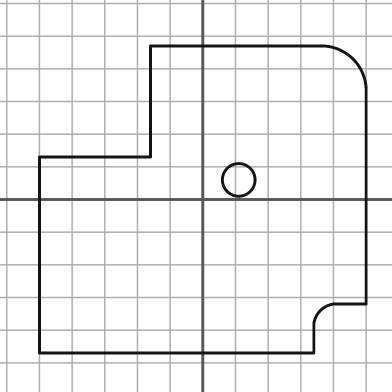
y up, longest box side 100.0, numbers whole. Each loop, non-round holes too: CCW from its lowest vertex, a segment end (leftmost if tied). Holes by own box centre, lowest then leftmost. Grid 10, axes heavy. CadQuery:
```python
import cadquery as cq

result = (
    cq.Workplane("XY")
    .moveTo(-50.0, -47.0)
    .lineTo(34.0, -47.0)
    .lineTo(34.0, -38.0)
    .threePointArc((36.0, -34.0), (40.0, -32.0))
    .lineTo(50.0, -32.0)
    .lineTo(50.0, 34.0)
    .threePointArc((46.0, 43.0), (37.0, 47.0))
    .lineTo(-16.0, 47.0)
    .lineTo(-16.0, 13.0)
    .lineTo(-50.0, 13.0)
    .close()
    .moveTo(11.0, 6.0)
    .circle(5.0)
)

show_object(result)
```